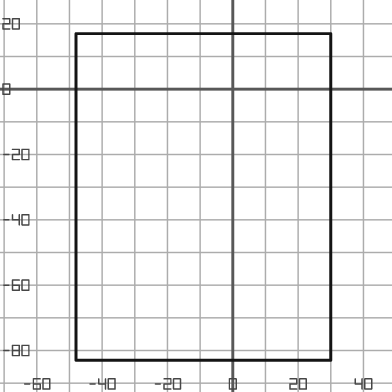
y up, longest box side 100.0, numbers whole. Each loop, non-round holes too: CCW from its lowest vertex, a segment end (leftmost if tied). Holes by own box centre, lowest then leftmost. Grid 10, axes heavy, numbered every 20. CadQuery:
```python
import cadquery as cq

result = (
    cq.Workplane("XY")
    .moveTo(-48.0, -83.0)
    .lineTo(30.0, -83.0)
    .lineTo(30.0, 17.0)
    .lineTo(-48.0, 17.0)
    .close()
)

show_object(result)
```